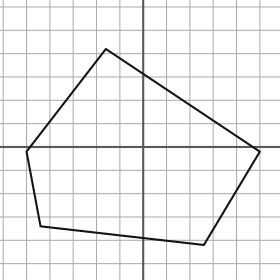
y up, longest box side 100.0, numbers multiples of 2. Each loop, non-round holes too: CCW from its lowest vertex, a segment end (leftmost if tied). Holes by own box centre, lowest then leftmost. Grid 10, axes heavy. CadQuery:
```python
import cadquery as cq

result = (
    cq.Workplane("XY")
    .moveTo(26.0, -42.0)
    .lineTo(50.0, -2.0)
    .lineTo(-16.0, 42.0)
    .lineTo(-50.0, -2.0)
    .lineTo(-44.0, -34.0)
    .close()
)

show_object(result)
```